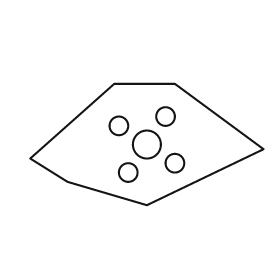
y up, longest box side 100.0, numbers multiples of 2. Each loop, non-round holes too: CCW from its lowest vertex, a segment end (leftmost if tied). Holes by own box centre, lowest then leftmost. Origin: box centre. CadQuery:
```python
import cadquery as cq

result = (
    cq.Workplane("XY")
    .moveTo(0.0, -26.0)
    .lineTo(50.0, -2.0)
    .lineTo(12.0, 26.0)
    .lineTo(-14.0, 26.0)
    .lineTo(-50.0, -6.0)
    .lineTo(-34.0, -16.0)
    .close()
    .moveTo(-8.0, -12.0)
    .circle(4.0)
    .moveTo(12.0, -8.0)
    .circle(4.0)
    .moveTo(0.0, 0.0)
    .circle(6.0)
    .moveTo(-12.0, 8.0)
    .circle(4.0)
    .moveTo(8.0, 12.0)
    .circle(4.0)
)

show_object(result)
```